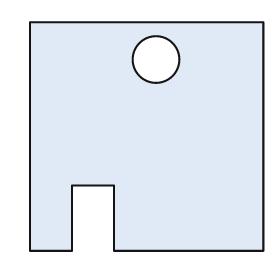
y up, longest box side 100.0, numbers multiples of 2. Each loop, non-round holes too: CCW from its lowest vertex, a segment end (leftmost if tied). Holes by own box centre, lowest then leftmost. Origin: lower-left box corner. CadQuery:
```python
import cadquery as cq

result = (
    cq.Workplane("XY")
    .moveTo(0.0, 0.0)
    .lineTo(18.0, 0.0)
    .lineTo(18.0, 28.0)
    .lineTo(36.0, 28.0)
    .lineTo(36.0, 0.0)
    .lineTo(100.0, 0.0)
    .lineTo(100.0, 98.0)
    .lineTo(0.0, 98.0)
    .close()
    .moveTo(54.0, 82.0)
    .circle(10.0)
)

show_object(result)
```